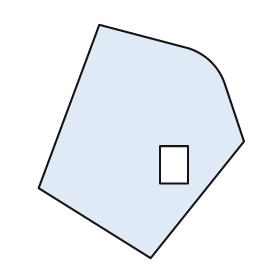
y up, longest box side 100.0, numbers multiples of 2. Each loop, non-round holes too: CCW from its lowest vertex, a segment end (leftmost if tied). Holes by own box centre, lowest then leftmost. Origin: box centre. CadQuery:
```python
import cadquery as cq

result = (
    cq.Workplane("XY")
    .moveTo(4.0, -50.0)
    .lineTo(44.0, 0.0)
    .lineTo(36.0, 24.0)
    .threePointArc((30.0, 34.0), (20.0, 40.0))
    .lineTo(-18.0, 50.0)
    .lineTo(-44.0, -20.0)
    .close()
    .moveTo(8.0, -18.0)
    .lineTo(20.0, -18.0)
    .lineTo(20.0, -2.0)
    .lineTo(8.0, -2.0)
    .close()
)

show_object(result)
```